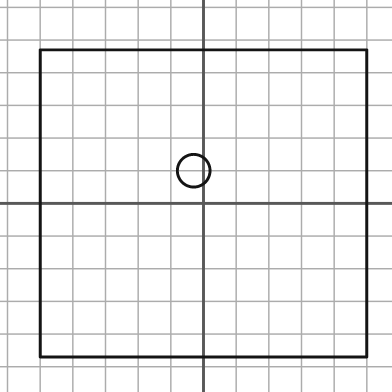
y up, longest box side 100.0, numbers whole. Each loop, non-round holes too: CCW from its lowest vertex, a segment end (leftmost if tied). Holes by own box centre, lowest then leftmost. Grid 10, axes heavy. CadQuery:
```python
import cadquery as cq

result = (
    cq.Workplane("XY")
    .moveTo(-50.0, -47.0)
    .lineTo(50.0, -47.0)
    .lineTo(50.0, 47.0)
    .lineTo(-50.0, 47.0)
    .close()
    .moveTo(-3.0, 10.0)
    .circle(5.0)
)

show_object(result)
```